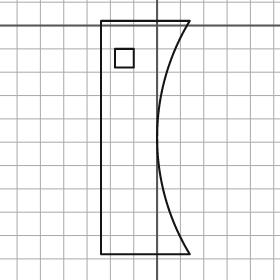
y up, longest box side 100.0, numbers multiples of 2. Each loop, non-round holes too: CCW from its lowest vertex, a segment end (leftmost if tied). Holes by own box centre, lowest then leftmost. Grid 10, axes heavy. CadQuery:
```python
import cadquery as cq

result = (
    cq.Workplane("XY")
    .moveTo(-24.0, -98.0)
    .lineTo(14.0, -98.0)
    .threePointArc((0.0, -48.0), (14.0, 2.0))
    .lineTo(-24.0, 2.0)
    .close()
    .moveTo(-18.0, -18.0)
    .lineTo(-10.0, -18.0)
    .lineTo(-10.0, -10.0)
    .lineTo(-18.0, -10.0)
    .close()
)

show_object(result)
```